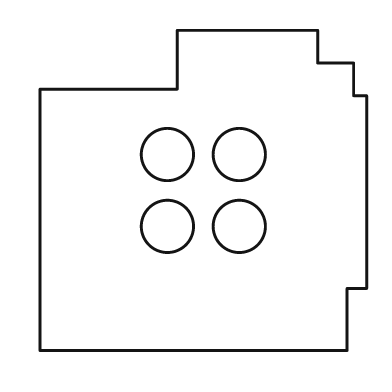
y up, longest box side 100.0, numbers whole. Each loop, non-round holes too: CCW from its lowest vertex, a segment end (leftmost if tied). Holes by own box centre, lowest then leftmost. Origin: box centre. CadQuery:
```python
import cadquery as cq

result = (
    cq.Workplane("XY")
    .moveTo(-50.0, -49.0)
    .lineTo(44.0, -49.0)
    .lineTo(44.0, -30.0)
    .lineTo(50.0, -30.0)
    .lineTo(50.0, 29.0)
    .lineTo(46.0, 29.0)
    .lineTo(46.0, 39.0)
    .lineTo(35.0, 39.0)
    .lineTo(35.0, 49.0)
    .lineTo(-8.0, 49.0)
    .lineTo(-8.0, 31.0)
    .lineTo(-50.0, 31.0)
    .close()
    .moveTo(-11.0, -11.0)
    .circle(8.0)
    .moveTo(11.0, -11.0)
    .circle(8.0)
    .moveTo(-11.0, 11.0)
    .circle(8.0)
    .moveTo(11.0, 11.0)
    .circle(8.0)
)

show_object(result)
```